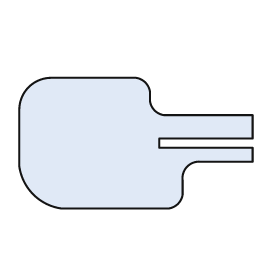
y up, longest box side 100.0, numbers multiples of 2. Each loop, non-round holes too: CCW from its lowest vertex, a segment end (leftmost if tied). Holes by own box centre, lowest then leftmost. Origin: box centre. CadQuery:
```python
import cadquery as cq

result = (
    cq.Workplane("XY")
    .moveTo(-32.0, -28.0)
    .lineTo(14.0, -28.0)
    .threePointArc((18.0, -26.0), (20.0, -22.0))
    .lineTo(20.0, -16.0)
    .threePointArc((22.0, -10.0), (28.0, -8.0))
    .lineTo(50.0, -8.0)
    .lineTo(50.0, -2.0)
    .lineTo(10.0, -2.0)
    .lineTo(10.0, 2.0)
    .lineTo(50.0, 2.0)
    .lineTo(50.0, 12.0)
    .lineTo(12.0, 12.0)
    .threePointArc((8.0, 14.0), (6.0, 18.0))
    .lineTo(6.0, 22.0)
    .threePointArc((4.0, 26.0), (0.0, 28.0))
    .lineTo(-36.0, 28.0)
    .threePointArc((-46.0, 24.0), (-50.0, 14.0))
    .lineTo(-50.0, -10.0)
    .threePointArc((-44.0, -22.0), (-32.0, -28.0))
    .close()
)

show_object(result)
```